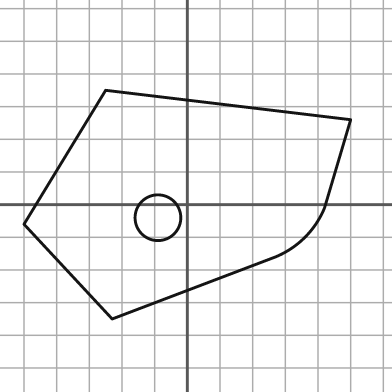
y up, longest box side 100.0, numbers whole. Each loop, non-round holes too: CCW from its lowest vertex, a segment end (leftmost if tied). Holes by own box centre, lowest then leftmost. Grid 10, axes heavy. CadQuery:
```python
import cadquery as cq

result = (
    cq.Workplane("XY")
    .moveTo(-23.0, -35.0)
    .lineTo(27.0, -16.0)
    .threePointArc((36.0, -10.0), (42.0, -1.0))
    .lineTo(50.0, 26.0)
    .lineTo(-25.0, 35.0)
    .lineTo(-50.0, -6.0)
    .close()
    .moveTo(-9.0, -4.0)
    .circle(7.0)
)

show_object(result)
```